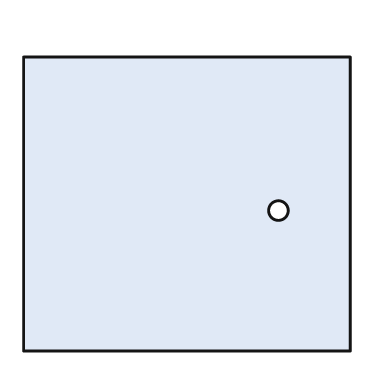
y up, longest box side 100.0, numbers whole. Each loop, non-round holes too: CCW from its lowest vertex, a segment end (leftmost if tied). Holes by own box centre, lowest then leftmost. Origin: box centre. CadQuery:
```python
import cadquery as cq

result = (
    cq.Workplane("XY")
    .moveTo(-50.0, -45.0)
    .lineTo(50.0, -45.0)
    .lineTo(50.0, 45.0)
    .lineTo(-50.0, 45.0)
    .close()
    .moveTo(28.0, -2.0)
    .circle(3.0)
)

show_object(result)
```